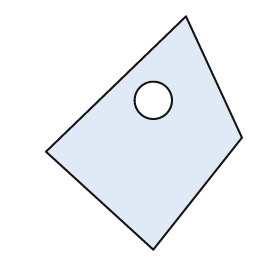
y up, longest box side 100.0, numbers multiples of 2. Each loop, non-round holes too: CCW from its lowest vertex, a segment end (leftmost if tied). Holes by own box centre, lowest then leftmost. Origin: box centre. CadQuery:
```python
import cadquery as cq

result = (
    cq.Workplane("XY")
    .moveTo(4.0, -50.0)
    .lineTo(42.0, -2.0)
    .lineTo(18.0, 50.0)
    .lineTo(-42.0, -8.0)
    .close()
    .moveTo(4.0, 14.0)
    .circle(8.0)
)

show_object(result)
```